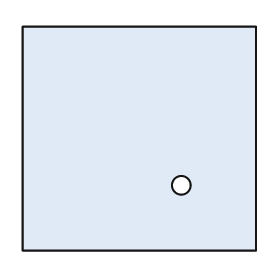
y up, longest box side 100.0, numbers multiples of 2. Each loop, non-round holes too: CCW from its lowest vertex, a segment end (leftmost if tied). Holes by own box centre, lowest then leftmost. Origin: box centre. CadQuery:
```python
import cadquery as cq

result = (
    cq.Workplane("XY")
    .moveTo(-50.0, -48.0)
    .lineTo(50.0, -48.0)
    .lineTo(50.0, 48.0)
    .lineTo(-50.0, 48.0)
    .close()
    .moveTo(18.0, -20.0)
    .circle(4.0)
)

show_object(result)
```